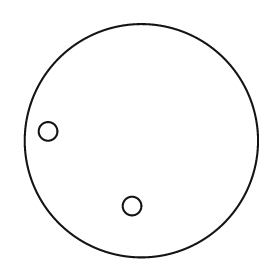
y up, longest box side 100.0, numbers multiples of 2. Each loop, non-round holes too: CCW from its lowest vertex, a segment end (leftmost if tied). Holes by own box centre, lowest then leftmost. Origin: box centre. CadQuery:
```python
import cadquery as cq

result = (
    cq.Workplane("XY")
    .moveTo(0.0, 0.0)
    .circle(50.0)
    .moveTo(-4.0, -28.0)
    .circle(4.0)
    .moveTo(-40.0, 4.0)
    .circle(4.0)
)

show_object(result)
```